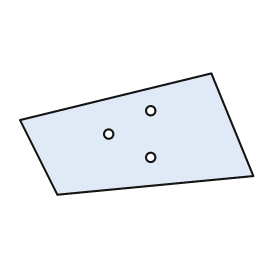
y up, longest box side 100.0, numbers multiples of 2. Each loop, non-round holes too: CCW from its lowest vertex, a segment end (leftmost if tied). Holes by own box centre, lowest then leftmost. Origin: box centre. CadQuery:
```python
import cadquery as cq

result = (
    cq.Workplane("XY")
    .moveTo(-34.0, -26.0)
    .lineTo(50.0, -18.0)
    .lineTo(32.0, 26.0)
    .lineTo(-50.0, 6.0)
    .close()
    .moveTo(6.0, -10.0)
    .circle(2.0)
    .moveTo(-12.0, 0.0)
    .circle(2.0)
    .moveTo(6.0, 10.0)
    .circle(2.0)
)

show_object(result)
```